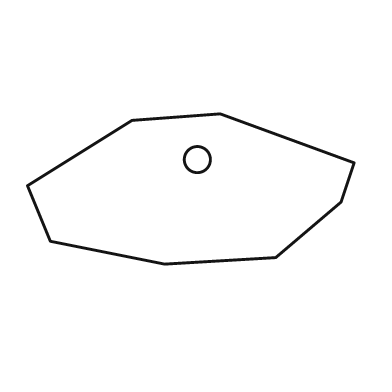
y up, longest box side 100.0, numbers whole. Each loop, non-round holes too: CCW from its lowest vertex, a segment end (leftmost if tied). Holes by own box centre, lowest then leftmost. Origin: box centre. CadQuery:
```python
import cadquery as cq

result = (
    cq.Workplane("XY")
    .moveTo(-8.0, -23.0)
    .lineTo(26.0, -21.0)
    .lineTo(46.0, -4.0)
    .lineTo(50.0, 8.0)
    .lineTo(9.0, 23.0)
    .lineTo(-18.0, 21.0)
    .lineTo(-50.0, 1.0)
    .lineTo(-43.0, -16.0)
    .close()
    .moveTo(2.0, 9.0)
    .circle(4.0)
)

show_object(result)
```